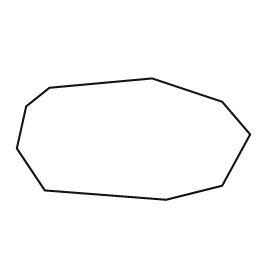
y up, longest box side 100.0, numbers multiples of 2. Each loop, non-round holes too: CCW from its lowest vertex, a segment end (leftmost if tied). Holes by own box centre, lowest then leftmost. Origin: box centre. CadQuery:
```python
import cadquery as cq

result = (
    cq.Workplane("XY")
    .moveTo(14.0, -26.0)
    .lineTo(38.0, -20.0)
    .lineTo(50.0, 2.0)
    .lineTo(38.0, 16.0)
    .lineTo(8.0, 26.0)
    .lineTo(-36.0, 22.0)
    .lineTo(-46.0, 14.0)
    .lineTo(-50.0, -4.0)
    .lineTo(-38.0, -22.0)
    .close()
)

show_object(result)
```